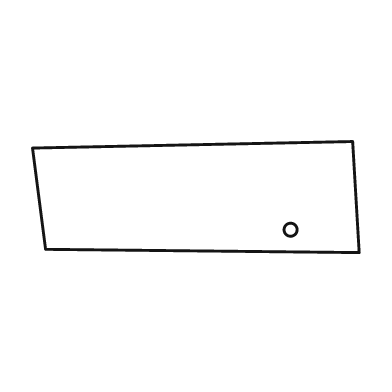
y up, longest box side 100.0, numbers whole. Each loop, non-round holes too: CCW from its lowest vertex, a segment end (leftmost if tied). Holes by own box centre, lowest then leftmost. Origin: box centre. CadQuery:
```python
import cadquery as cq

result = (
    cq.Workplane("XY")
    .moveTo(50.0, -17.0)
    .lineTo(48.0, 17.0)
    .lineTo(-50.0, 15.0)
    .lineTo(-46.0, -16.0)
    .close()
    .moveTo(29.0, -10.0)
    .circle(2.0)
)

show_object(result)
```